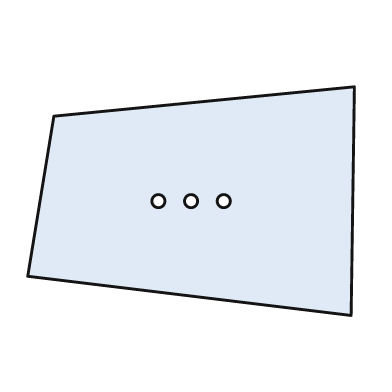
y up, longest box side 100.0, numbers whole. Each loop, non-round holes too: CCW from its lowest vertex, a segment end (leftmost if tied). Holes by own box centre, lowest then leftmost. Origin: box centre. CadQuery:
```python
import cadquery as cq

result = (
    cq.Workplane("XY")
    .moveTo(49.0, -35.0)
    .lineTo(50.0, 35.0)
    .lineTo(-42.0, 26.0)
    .lineTo(-50.0, -23.0)
    .close()
    .moveTo(-10.0, 0.0)
    .circle(2.0)
    .moveTo(0.0, 0.0)
    .circle(2.0)
    .moveTo(10.0, 0.0)
    .circle(2.0)
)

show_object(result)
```